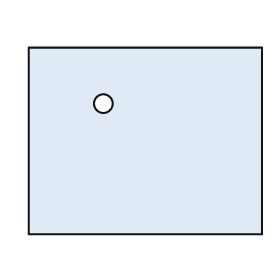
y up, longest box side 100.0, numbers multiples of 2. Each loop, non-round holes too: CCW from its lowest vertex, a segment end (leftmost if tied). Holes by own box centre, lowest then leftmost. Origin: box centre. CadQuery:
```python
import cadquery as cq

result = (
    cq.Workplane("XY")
    .moveTo(-50.0, -40.0)
    .lineTo(50.0, -40.0)
    .lineTo(50.0, 40.0)
    .lineTo(-50.0, 40.0)
    .close()
    .moveTo(-18.0, 16.0)
    .circle(4.0)
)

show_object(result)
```